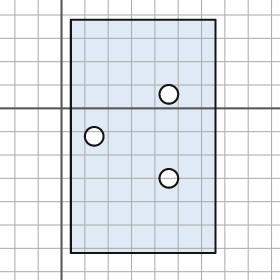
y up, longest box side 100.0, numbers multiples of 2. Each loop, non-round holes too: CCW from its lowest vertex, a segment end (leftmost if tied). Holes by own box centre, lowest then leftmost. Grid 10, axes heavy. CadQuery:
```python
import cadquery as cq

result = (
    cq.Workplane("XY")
    .moveTo(4.0, -62.0)
    .lineTo(66.0, -62.0)
    .lineTo(66.0, 38.0)
    .lineTo(4.0, 38.0)
    .close()
    .moveTo(46.0, -30.0)
    .circle(4.0)
    .moveTo(14.0, -12.0)
    .circle(4.0)
    .moveTo(46.0, 6.0)
    .circle(4.0)
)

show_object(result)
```